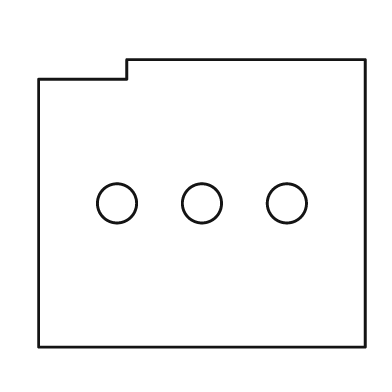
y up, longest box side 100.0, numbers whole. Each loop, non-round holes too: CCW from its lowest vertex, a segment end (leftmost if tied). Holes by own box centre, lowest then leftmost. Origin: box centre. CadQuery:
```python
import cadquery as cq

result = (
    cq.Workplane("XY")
    .moveTo(-50.0, -44.0)
    .lineTo(50.0, -44.0)
    .lineTo(50.0, 44.0)
    .lineTo(-23.0, 44.0)
    .lineTo(-23.0, 38.0)
    .lineTo(-50.0, 38.0)
    .close()
    .moveTo(-26.0, 0.0)
    .circle(6.0)
    .moveTo(0.0, 0.0)
    .circle(6.0)
    .moveTo(26.0, 0.0)
    .circle(6.0)
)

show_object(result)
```